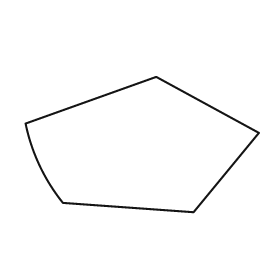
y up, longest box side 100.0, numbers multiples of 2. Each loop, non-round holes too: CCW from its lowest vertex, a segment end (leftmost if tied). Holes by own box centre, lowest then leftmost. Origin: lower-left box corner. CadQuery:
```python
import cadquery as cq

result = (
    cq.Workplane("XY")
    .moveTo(72.0, 0.0)
    .lineTo(100.0, 34.0)
    .lineTo(56.0, 58.0)
    .lineTo(0.0, 38.0)
    .threePointArc((6.0, 20.0), (16.0, 4.0))
    .close()
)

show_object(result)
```